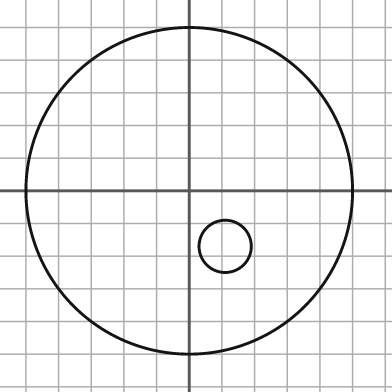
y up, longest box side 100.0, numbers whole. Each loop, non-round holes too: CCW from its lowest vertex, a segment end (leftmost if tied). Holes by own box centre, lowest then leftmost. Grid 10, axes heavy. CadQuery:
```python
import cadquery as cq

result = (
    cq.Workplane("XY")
    .moveTo(0.0, 0.0)
    .circle(50.0)
    .moveTo(11.0, -17.0)
    .circle(8.0)
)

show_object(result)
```